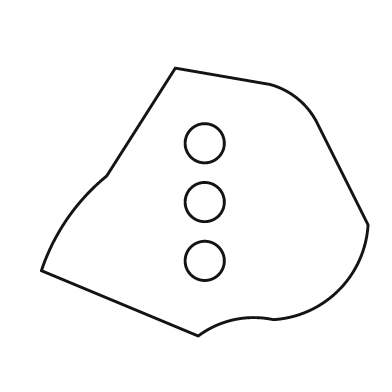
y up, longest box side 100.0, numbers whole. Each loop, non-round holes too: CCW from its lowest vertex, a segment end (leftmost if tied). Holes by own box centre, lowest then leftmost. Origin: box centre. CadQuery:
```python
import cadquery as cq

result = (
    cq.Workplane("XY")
    .moveTo(-2.0, -41.0)
    .threePointArc((9.0, -36.0), (21.0, -36.0))
    .threePointArc((41.0, -27.0), (50.0, -7.0))
    .lineTo(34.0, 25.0)
    .threePointArc((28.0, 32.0), (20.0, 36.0))
    .lineTo(-9.0, 41.0)
    .lineTo(-30.0, 8.0)
    .threePointArc((-42.0, -5.0), (-50.0, -21.0))
    .close()
    .moveTo(0.0, -18.0)
    .circle(6.0)
    .moveTo(0.0, 0.0)
    .circle(6.0)
    .moveTo(0.0, 18.0)
    .circle(6.0)
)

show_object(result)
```